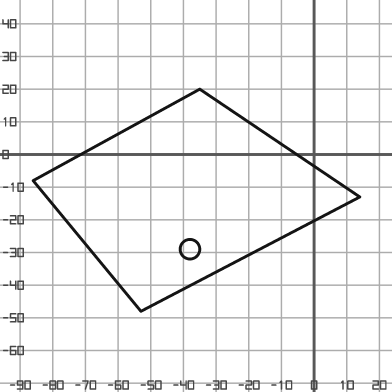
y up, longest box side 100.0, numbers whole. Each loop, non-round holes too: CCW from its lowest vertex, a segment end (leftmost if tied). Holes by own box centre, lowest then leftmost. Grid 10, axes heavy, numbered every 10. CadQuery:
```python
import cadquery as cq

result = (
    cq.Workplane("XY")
    .moveTo(-53.0, -48.0)
    .lineTo(14.0, -13.0)
    .lineTo(-35.0, 20.0)
    .lineTo(-86.0, -8.0)
    .close()
    .moveTo(-38.0, -29.0)
    .circle(3.0)
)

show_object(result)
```